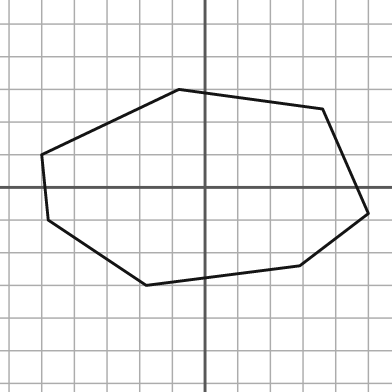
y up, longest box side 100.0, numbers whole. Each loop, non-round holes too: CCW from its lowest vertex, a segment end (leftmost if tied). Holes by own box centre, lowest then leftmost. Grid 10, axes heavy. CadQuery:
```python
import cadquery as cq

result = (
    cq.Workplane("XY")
    .moveTo(-18.0, -30.0)
    .lineTo(29.0, -24.0)
    .lineTo(50.0, -8.0)
    .lineTo(36.0, 24.0)
    .lineTo(-8.0, 30.0)
    .lineTo(-50.0, 10.0)
    .lineTo(-48.0, -10.0)
    .close()
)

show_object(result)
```